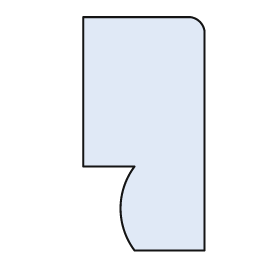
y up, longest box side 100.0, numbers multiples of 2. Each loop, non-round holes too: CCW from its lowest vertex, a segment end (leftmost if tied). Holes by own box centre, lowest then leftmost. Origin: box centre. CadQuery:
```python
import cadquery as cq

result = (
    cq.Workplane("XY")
    .moveTo(-4.0, -50.0)
    .lineTo(26.0, -50.0)
    .lineTo(26.0, 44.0)
    .threePointArc((24.0, 48.0), (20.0, 50.0))
    .lineTo(-26.0, 50.0)
    .lineTo(-26.0, -14.0)
    .lineTo(-4.0, -14.0)
    .threePointArc((-10.0, -32.0), (-4.0, -50.0))
    .close()
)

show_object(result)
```